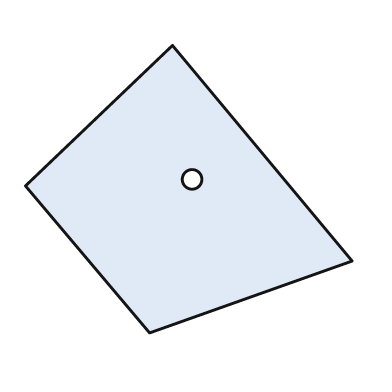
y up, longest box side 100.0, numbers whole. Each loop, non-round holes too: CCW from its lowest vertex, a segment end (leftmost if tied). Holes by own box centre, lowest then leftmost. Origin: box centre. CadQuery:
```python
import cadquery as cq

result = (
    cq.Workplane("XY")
    .moveTo(-12.0, -44.0)
    .lineTo(50.0, -22.0)
    .lineTo(-5.0, 44.0)
    .lineTo(-50.0, 1.0)
    .close()
    .moveTo(1.0, 3.0)
    .circle(3.0)
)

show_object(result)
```